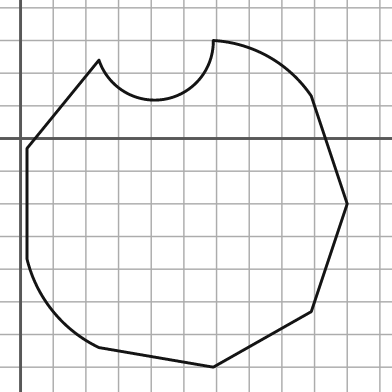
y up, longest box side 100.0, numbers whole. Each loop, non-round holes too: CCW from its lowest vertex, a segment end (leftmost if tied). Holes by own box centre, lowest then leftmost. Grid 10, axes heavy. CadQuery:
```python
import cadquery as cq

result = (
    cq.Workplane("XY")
    .moveTo(59.0, -70.0)
    .lineTo(89.0, -53.0)
    .lineTo(100.0, -20.0)
    .lineTo(89.0, 13.0)
    .threePointArc((76.0, 25.0), (59.0, 30.0))
    .threePointArc((44.0, 12.0), (24.0, 24.0))
    .lineTo(2.0, -3.0)
    .lineTo(2.0, -37.0)
    .threePointArc((10.0, -53.0), (24.0, -64.0))
    .close()
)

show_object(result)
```